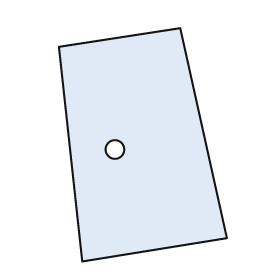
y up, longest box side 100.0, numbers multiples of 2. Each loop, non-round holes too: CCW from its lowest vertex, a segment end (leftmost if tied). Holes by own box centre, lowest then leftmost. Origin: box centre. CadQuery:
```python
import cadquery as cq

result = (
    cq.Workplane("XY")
    .moveTo(-26.0, -50.0)
    .lineTo(36.0, -40.0)
    .lineTo(16.0, 50.0)
    .lineTo(-36.0, 42.0)
    .close()
    .moveTo(-12.0, -2.0)
    .circle(4.0)
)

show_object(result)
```